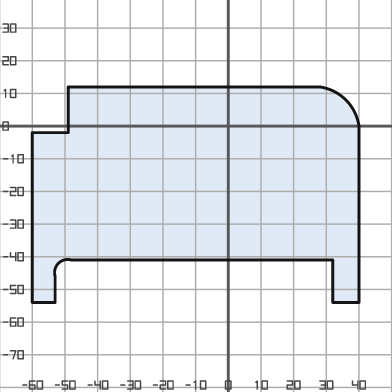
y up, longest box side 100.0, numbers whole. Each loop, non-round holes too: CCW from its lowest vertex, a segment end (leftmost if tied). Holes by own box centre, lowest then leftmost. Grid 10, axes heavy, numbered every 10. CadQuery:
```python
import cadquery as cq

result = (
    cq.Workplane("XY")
    .moveTo(-60.0, -54.0)
    .lineTo(-53.0, -54.0)
    .lineTo(-53.0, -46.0)
    .threePointArc((-52.0, -42.0), (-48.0, -41.0))
    .lineTo(32.0, -41.0)
    .lineTo(32.0, -54.0)
    .lineTo(40.0, -54.0)
    .lineTo(40.0, 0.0)
    .threePointArc((36.0, 8.0), (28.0, 12.0))
    .lineTo(-49.0, 12.0)
    .lineTo(-49.0, -2.0)
    .lineTo(-60.0, -2.0)
    .close()
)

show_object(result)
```